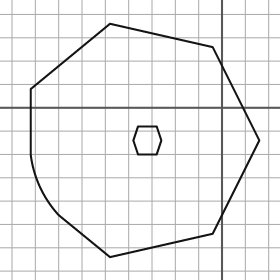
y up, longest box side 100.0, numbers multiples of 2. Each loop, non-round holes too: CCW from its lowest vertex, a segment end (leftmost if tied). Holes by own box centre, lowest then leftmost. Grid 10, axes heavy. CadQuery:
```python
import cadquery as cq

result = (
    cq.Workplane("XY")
    .moveTo(-48.0, -64.0)
    .lineTo(-4.0, -54.0)
    .lineTo(16.0, -14.0)
    .lineTo(-4.0, 26.0)
    .lineTo(-48.0, 36.0)
    .lineTo(-82.0, 8.0)
    .lineTo(-82.0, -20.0)
    .threePointArc((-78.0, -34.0), (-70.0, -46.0))
    .close()
    .moveTo(-36.0, -20.0)
    .lineTo(-28.0, -20.0)
    .lineTo(-26.0, -14.0)
    .lineTo(-28.0, -8.0)
    .lineTo(-36.0, -8.0)
    .lineTo(-38.0, -14.0)
    .close()
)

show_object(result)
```